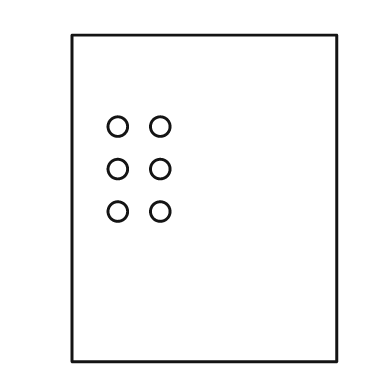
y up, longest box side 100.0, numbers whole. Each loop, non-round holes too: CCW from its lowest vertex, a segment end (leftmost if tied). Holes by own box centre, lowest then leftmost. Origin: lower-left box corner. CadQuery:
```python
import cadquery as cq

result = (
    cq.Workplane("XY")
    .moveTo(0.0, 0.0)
    .lineTo(81.0, 0.0)
    .lineTo(81.0, 100.0)
    .lineTo(0.0, 100.0)
    .close()
    .moveTo(14.0, 46.0)
    .circle(3.0)
    .moveTo(27.0, 46.0)
    .circle(3.0)
    .moveTo(14.0, 59.0)
    .circle(3.0)
    .moveTo(27.0, 59.0)
    .circle(3.0)
    .moveTo(14.0, 72.0)
    .circle(3.0)
    .moveTo(27.0, 72.0)
    .circle(3.0)
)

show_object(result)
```